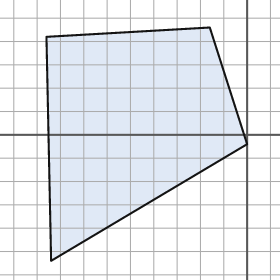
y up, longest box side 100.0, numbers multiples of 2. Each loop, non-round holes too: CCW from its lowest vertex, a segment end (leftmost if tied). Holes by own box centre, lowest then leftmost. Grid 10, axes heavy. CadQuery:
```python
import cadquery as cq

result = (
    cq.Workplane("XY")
    .moveTo(-84.0, -54.0)
    .lineTo(0.0, -4.0)
    .lineTo(-16.0, 46.0)
    .lineTo(-86.0, 42.0)
    .close()
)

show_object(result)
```